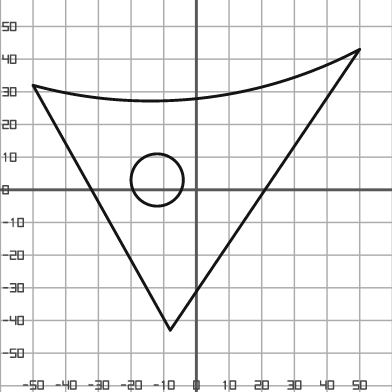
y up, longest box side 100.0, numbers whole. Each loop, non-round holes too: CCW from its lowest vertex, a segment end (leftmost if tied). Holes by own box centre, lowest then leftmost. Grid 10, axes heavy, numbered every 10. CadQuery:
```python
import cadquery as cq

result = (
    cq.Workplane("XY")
    .moveTo(-8.0, -43.0)
    .lineTo(50.0, 43.0)
    .threePointArc((1.0, 28.0), (-50.0, 32.0))
    .close()
    .moveTo(-12.0, 3.0)
    .circle(8.0)
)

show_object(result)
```